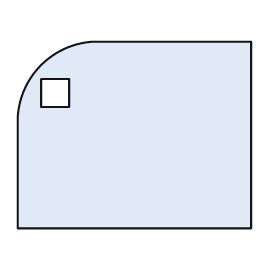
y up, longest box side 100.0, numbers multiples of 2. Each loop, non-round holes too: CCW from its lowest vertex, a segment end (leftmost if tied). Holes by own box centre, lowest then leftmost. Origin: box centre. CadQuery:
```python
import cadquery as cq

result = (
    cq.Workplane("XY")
    .moveTo(-50.0, -40.0)
    .lineTo(50.0, -40.0)
    .lineTo(50.0, 40.0)
    .lineTo(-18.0, 40.0)
    .threePointArc((-40.0, 30.0), (-50.0, 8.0))
    .close()
    .moveTo(-40.0, 12.0)
    .lineTo(-28.0, 12.0)
    .lineTo(-28.0, 24.0)
    .lineTo(-40.0, 24.0)
    .close()
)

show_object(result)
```